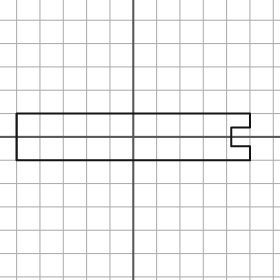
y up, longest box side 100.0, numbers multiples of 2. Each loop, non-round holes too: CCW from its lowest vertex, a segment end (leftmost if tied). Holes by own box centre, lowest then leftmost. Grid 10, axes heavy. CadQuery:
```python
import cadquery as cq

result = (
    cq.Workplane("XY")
    .moveTo(-50.0, -10.0)
    .lineTo(50.0, -10.0)
    .lineTo(50.0, -4.0)
    .lineTo(42.0, -4.0)
    .lineTo(42.0, 4.0)
    .lineTo(50.0, 4.0)
    .lineTo(50.0, 10.0)
    .lineTo(-50.0, 10.0)
    .close()
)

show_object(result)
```